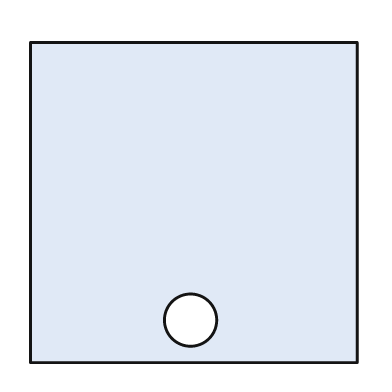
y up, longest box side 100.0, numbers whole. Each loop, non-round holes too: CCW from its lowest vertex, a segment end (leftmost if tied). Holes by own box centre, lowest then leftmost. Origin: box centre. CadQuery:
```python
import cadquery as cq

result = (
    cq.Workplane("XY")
    .moveTo(-50.0, -49.0)
    .lineTo(50.0, -49.0)
    .lineTo(50.0, 49.0)
    .lineTo(-50.0, 49.0)
    .close()
    .moveTo(-1.0, -36.0)
    .circle(8.0)
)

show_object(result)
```